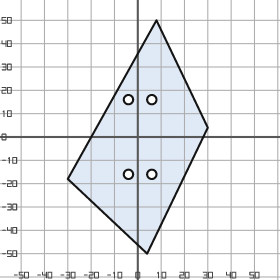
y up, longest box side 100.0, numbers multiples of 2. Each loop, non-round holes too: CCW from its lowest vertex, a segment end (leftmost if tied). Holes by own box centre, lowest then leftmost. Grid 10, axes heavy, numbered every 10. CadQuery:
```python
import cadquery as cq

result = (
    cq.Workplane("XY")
    .moveTo(4.0, -50.0)
    .lineTo(30.0, 4.0)
    .lineTo(8.0, 50.0)
    .lineTo(-30.0, -18.0)
    .close()
    .moveTo(-4.0, -16.0)
    .circle(2.0)
    .moveTo(6.0, -16.0)
    .circle(2.0)
    .moveTo(-4.0, 16.0)
    .circle(2.0)
    .moveTo(6.0, 16.0)
    .circle(2.0)
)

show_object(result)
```